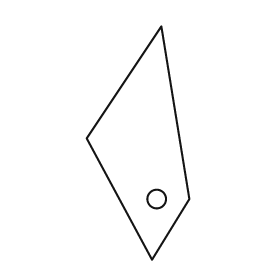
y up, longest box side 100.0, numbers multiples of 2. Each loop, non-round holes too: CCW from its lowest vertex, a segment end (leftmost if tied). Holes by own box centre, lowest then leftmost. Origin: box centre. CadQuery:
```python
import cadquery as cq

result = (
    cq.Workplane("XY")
    .moveTo(6.0, -50.0)
    .lineTo(22.0, -24.0)
    .lineTo(10.0, 50.0)
    .lineTo(-22.0, 2.0)
    .close()
    .moveTo(8.0, -24.0)
    .circle(4.0)
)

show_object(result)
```